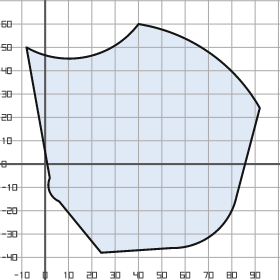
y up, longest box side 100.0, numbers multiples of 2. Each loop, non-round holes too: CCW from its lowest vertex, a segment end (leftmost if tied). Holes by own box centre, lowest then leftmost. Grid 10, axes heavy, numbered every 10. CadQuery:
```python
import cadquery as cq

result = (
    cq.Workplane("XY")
    .moveTo(24.0, -38.0)
    .lineTo(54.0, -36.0)
    .threePointArc((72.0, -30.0), (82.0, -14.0))
    .lineTo(92.0, 24.0)
    .threePointArc((70.0, 48.0), (40.0, 60.0))
    .threePointArc((18.0, 46.0), (-8.0, 50.0))
    .lineTo(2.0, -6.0)
    .threePointArc((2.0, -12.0), (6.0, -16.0))
    .close()
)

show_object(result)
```